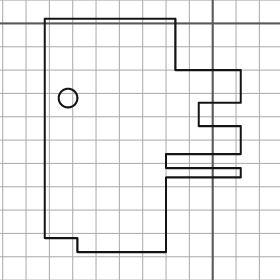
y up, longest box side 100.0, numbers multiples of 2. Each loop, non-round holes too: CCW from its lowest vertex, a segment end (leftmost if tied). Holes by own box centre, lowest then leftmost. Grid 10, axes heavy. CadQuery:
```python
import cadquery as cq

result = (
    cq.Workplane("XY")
    .moveTo(-58.0, -98.0)
    .lineTo(-20.0, -98.0)
    .lineTo(-20.0, -66.0)
    .lineTo(12.0, -66.0)
    .lineTo(12.0, -62.0)
    .lineTo(-20.0, -62.0)
    .lineTo(-20.0, -56.0)
    .lineTo(12.0, -56.0)
    .lineTo(12.0, -44.0)
    .lineTo(-6.0, -44.0)
    .lineTo(-6.0, -34.0)
    .lineTo(12.0, -34.0)
    .lineTo(12.0, -20.0)
    .lineTo(-16.0, -20.0)
    .lineTo(-16.0, 2.0)
    .lineTo(-72.0, 2.0)
    .lineTo(-72.0, -92.0)
    .lineTo(-58.0, -92.0)
    .close()
    .moveTo(-62.0, -32.0)
    .circle(4.0)
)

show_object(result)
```